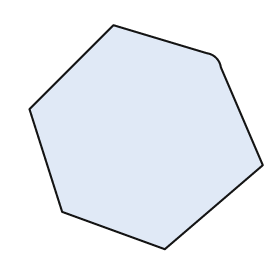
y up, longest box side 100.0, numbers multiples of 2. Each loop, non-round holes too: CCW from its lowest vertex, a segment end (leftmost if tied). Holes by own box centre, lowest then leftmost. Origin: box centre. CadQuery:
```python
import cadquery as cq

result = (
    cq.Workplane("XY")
    .moveTo(8.0, -48.0)
    .lineTo(50.0, -12.0)
    .lineTo(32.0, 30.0)
    .threePointArc((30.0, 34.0), (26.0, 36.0))
    .lineTo(-14.0, 48.0)
    .lineTo(-50.0, 12.0)
    .lineTo(-36.0, -32.0)
    .close()
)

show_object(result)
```